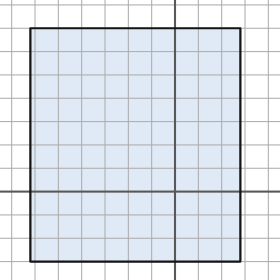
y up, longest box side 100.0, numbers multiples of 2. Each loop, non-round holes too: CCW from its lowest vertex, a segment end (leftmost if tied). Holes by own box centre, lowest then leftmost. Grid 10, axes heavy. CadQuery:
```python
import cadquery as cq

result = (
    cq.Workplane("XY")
    .moveTo(-62.0, -30.0)
    .lineTo(28.0, -30.0)
    .lineTo(28.0, 70.0)
    .lineTo(-62.0, 70.0)
    .close()
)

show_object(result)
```